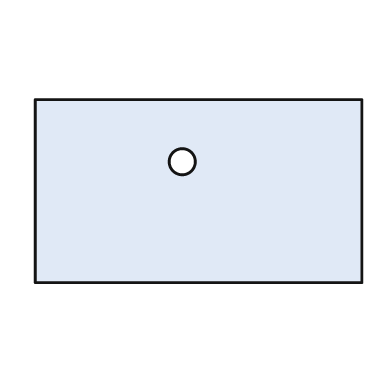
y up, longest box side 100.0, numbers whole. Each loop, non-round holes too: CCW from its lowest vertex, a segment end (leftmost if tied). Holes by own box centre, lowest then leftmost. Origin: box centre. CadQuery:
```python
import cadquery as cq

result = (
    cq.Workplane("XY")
    .moveTo(-50.0, -28.0)
    .lineTo(50.0, -28.0)
    .lineTo(50.0, 28.0)
    .lineTo(-50.0, 28.0)
    .close()
    .moveTo(-5.0, 9.0)
    .circle(4.0)
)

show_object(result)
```